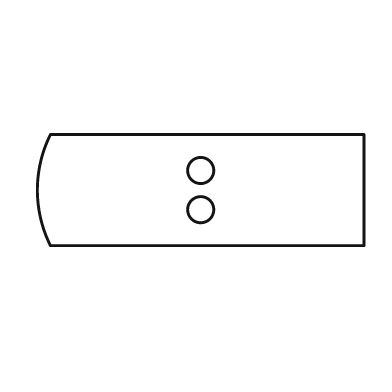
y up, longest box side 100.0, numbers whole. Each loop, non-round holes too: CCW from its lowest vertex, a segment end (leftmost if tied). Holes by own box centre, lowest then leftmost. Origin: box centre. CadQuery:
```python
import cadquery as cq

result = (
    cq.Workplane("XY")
    .moveTo(-46.0, -17.0)
    .lineTo(50.0, -17.0)
    .lineTo(50.0, 17.0)
    .lineTo(-46.0, 17.0)
    .threePointArc((-50.0, 0.0), (-46.0, -17.0))
    .close()
    .moveTo(0.0, -6.0)
    .circle(4.0)
    .moveTo(0.0, 6.0)
    .circle(4.0)
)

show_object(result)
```